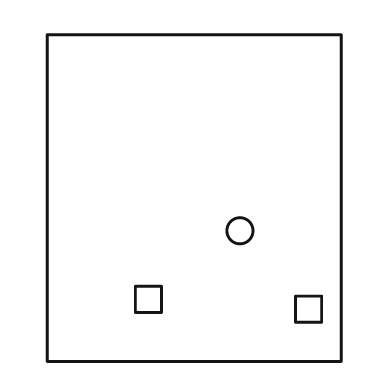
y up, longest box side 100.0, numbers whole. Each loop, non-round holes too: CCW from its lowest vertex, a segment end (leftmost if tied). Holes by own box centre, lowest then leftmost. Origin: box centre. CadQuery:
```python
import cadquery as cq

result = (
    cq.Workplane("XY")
    .moveTo(-45.0, -50.0)
    .lineTo(45.0, -50.0)
    .lineTo(45.0, 50.0)
    .lineTo(-45.0, 50.0)
    .close()
    .moveTo(31.0, -38.0)
    .lineTo(39.0, -38.0)
    .lineTo(39.0, -30.0)
    .lineTo(31.0, -30.0)
    .close()
    .moveTo(-18.0, -35.0)
    .lineTo(-10.0, -35.0)
    .lineTo(-10.0, -27.0)
    .lineTo(-18.0, -27.0)
    .close()
    .moveTo(14.0, -10.0)
    .circle(4.0)
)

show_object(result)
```